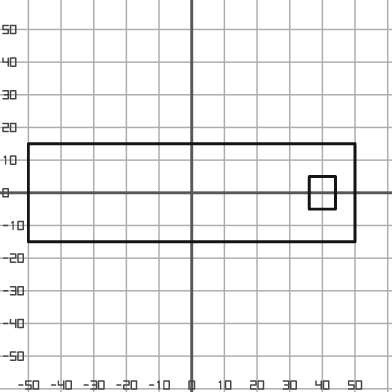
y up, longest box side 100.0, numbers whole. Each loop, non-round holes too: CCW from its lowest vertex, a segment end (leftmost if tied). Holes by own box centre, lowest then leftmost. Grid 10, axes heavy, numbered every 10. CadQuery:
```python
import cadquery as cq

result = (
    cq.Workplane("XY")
    .moveTo(-50.0, -15.0)
    .lineTo(50.0, -15.0)
    .lineTo(50.0, 15.0)
    .lineTo(-50.0, 15.0)
    .close()
    .moveTo(36.0, -5.0)
    .lineTo(44.0, -5.0)
    .lineTo(44.0, 5.0)
    .lineTo(36.0, 5.0)
    .close()
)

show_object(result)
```